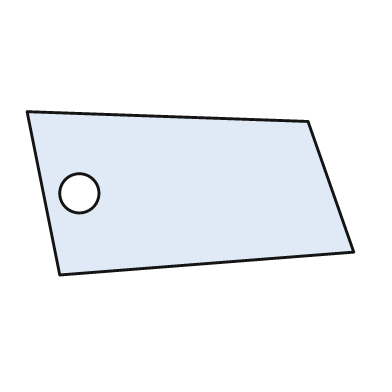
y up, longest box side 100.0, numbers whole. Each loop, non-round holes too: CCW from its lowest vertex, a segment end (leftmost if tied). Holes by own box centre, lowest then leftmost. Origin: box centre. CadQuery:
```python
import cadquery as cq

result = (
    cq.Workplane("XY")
    .moveTo(-40.0, -25.0)
    .lineTo(50.0, -18.0)
    .lineTo(36.0, 22.0)
    .lineTo(-50.0, 25.0)
    .close()
    .moveTo(-34.0, 0.0)
    .circle(6.0)
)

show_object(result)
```